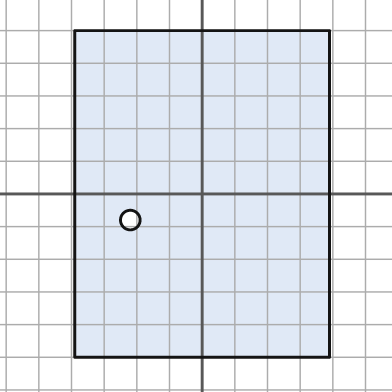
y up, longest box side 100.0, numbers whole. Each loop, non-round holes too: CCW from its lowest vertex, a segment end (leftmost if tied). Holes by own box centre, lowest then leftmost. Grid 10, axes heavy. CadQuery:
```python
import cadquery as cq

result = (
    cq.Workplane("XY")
    .moveTo(-39.0, -50.0)
    .lineTo(39.0, -50.0)
    .lineTo(39.0, 50.0)
    .lineTo(-39.0, 50.0)
    .close()
    .moveTo(-22.0, -8.0)
    .circle(3.0)
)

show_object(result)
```